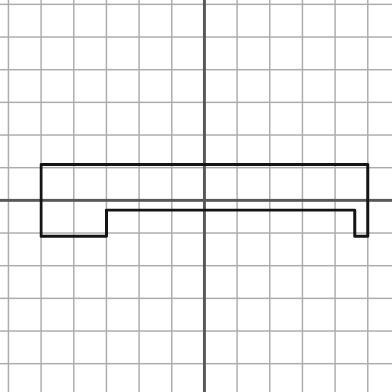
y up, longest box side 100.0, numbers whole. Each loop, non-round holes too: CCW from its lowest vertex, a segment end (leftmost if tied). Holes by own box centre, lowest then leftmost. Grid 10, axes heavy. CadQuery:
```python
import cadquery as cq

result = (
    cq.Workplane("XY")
    .moveTo(-50.0, -11.0)
    .lineTo(-30.0, -11.0)
    .lineTo(-30.0, -3.0)
    .lineTo(46.0, -3.0)
    .lineTo(46.0, -11.0)
    .lineTo(50.0, -11.0)
    .lineTo(50.0, 11.0)
    .lineTo(-50.0, 11.0)
    .close()
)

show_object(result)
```